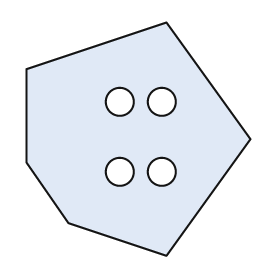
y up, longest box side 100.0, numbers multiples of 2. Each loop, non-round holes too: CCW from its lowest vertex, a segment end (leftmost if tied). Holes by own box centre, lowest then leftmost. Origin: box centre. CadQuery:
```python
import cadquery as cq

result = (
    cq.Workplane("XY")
    .moveTo(12.0, -50.0)
    .lineTo(48.0, 0.0)
    .lineTo(12.0, 50.0)
    .lineTo(-48.0, 30.0)
    .lineTo(-48.0, -10.0)
    .lineTo(-30.0, -36.0)
    .close()
    .moveTo(-8.0, -14.0)
    .circle(6.0)
    .moveTo(10.0, -14.0)
    .circle(6.0)
    .moveTo(-8.0, 16.0)
    .circle(6.0)
    .moveTo(10.0, 16.0)
    .circle(6.0)
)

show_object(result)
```